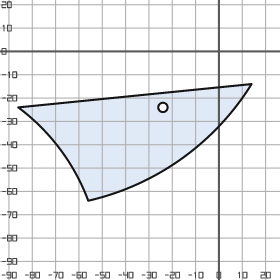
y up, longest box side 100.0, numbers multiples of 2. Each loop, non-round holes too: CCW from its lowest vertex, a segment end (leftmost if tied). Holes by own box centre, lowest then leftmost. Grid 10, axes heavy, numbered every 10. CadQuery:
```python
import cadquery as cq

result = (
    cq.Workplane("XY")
    .moveTo(-56.0, -64.0)
    .threePointArc((-16.0, -46.0), (14.0, -14.0))
    .lineTo(-86.0, -24.0)
    .threePointArc((-68.0, -42.0), (-56.0, -64.0))
    .close()
    .moveTo(-24.0, -24.0)
    .circle(2.0)
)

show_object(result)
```